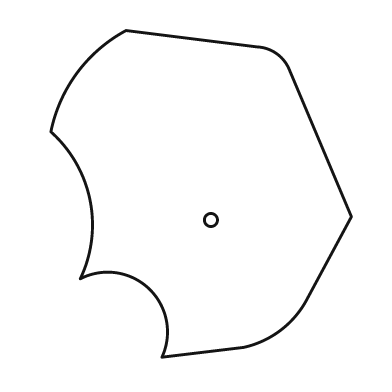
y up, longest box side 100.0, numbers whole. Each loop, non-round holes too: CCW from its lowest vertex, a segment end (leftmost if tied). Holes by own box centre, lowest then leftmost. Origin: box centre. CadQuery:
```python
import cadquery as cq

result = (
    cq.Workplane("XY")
    .moveTo(-12.0, -50.0)
    .lineTo(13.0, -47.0)
    .threePointArc((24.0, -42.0), (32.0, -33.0))
    .lineTo(46.0, -7.0)
    .lineTo(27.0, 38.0)
    .threePointArc((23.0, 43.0), (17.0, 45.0))
    .lineTo(-23.0, 50.0)
    .threePointArc((-38.0, 37.0), (-46.0, 19.0))
    .threePointArc((-34.0, -2.0), (-37.0, -26.0))
    .threePointArc((-16.0, -29.0), (-12.0, -50.0))
    .close()
    .moveTo(3.0, -8.0)
    .circle(2.0)
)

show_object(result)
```